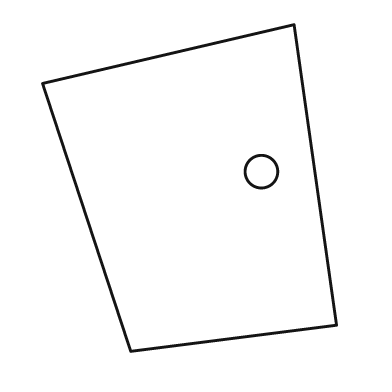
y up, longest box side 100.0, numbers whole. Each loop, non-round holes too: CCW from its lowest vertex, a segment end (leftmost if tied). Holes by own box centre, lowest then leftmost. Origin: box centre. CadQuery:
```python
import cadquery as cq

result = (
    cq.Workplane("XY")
    .moveTo(-18.0, -50.0)
    .lineTo(45.0, -42.0)
    .lineTo(32.0, 50.0)
    .lineTo(-45.0, 32.0)
    .close()
    .moveTo(22.0, 5.0)
    .circle(5.0)
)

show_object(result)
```